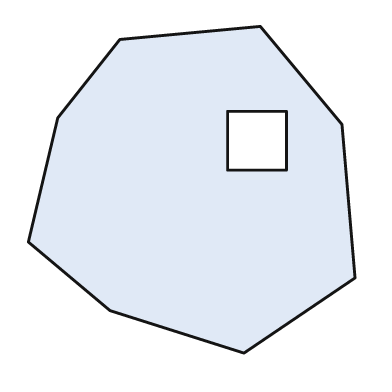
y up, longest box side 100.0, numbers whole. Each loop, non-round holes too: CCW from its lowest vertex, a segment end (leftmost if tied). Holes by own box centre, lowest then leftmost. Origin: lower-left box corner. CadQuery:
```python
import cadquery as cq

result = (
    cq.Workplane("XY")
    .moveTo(66.0, 0.0)
    .lineTo(100.0, 23.0)
    .lineTo(96.0, 70.0)
    .lineTo(71.0, 100.0)
    .lineTo(28.0, 96.0)
    .lineTo(9.0, 72.0)
    .lineTo(0.0, 34.0)
    .lineTo(25.0, 13.0)
    .close()
    .moveTo(61.0, 56.0)
    .lineTo(79.0, 56.0)
    .lineTo(79.0, 74.0)
    .lineTo(61.0, 74.0)
    .close()
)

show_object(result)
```